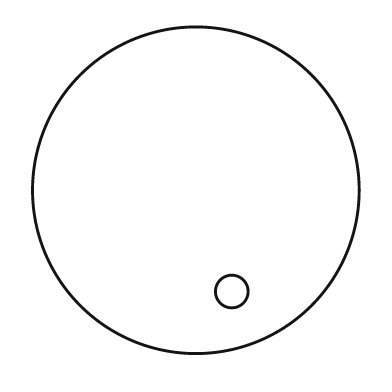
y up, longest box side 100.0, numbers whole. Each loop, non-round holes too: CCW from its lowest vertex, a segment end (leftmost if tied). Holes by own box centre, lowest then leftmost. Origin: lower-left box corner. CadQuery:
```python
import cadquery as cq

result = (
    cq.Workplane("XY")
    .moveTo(50.0, 50.0)
    .circle(50.0)
    .moveTo(61.0, 19.0)
    .circle(5.0)
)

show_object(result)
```